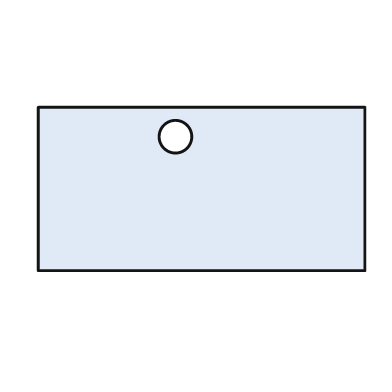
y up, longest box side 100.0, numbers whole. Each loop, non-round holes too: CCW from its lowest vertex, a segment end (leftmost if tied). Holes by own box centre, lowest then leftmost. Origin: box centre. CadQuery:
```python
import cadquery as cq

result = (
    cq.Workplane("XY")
    .moveTo(-50.0, -25.0)
    .lineTo(50.0, -25.0)
    .lineTo(50.0, 25.0)
    .lineTo(-50.0, 25.0)
    .close()
    .moveTo(-8.0, 16.0)
    .circle(5.0)
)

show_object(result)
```